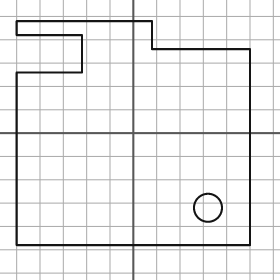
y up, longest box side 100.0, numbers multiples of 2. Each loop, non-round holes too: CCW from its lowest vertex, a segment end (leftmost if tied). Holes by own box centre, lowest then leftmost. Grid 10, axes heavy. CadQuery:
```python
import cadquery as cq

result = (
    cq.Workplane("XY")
    .moveTo(-50.0, -48.0)
    .lineTo(50.0, -48.0)
    .lineTo(50.0, 36.0)
    .lineTo(8.0, 36.0)
    .lineTo(8.0, 48.0)
    .lineTo(-50.0, 48.0)
    .lineTo(-50.0, 42.0)
    .lineTo(-22.0, 42.0)
    .lineTo(-22.0, 26.0)
    .lineTo(-50.0, 26.0)
    .close()
    .moveTo(32.0, -32.0)
    .circle(6.0)
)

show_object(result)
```